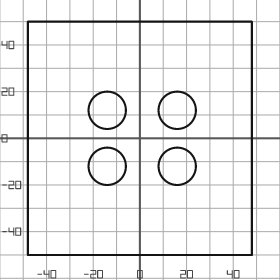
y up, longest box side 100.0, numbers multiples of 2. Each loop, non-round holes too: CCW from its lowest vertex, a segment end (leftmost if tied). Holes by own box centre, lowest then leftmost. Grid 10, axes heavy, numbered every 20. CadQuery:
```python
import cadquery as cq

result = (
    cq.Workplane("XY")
    .moveTo(-48.0, -50.0)
    .lineTo(48.0, -50.0)
    .lineTo(48.0, 50.0)
    .lineTo(-48.0, 50.0)
    .close()
    .moveTo(-14.0, -12.0)
    .circle(8.0)
    .moveTo(16.0, -12.0)
    .circle(8.0)
    .moveTo(-14.0, 12.0)
    .circle(8.0)
    .moveTo(16.0, 12.0)
    .circle(8.0)
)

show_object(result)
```